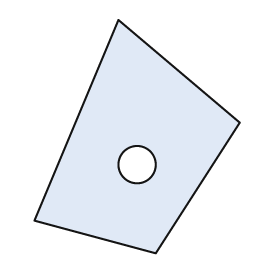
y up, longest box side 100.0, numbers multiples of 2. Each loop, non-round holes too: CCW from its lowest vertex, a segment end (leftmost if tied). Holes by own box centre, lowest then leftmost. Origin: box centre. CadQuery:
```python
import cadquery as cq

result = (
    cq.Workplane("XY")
    .moveTo(8.0, -50.0)
    .lineTo(44.0, 6.0)
    .lineTo(-8.0, 50.0)
    .lineTo(-44.0, -36.0)
    .close()
    .moveTo(0.0, -12.0)
    .circle(8.0)
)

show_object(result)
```